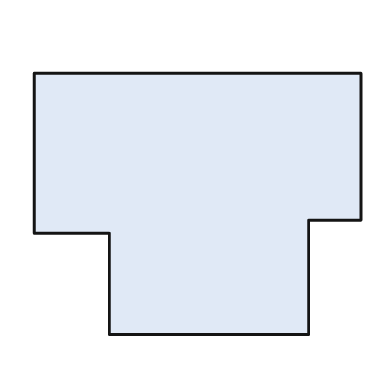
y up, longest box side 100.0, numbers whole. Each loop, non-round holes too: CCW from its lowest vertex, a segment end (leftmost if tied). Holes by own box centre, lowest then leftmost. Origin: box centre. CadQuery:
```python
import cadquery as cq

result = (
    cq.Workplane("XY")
    .moveTo(-27.0, -40.0)
    .lineTo(34.0, -40.0)
    .lineTo(34.0, -5.0)
    .lineTo(50.0, -5.0)
    .lineTo(50.0, 40.0)
    .lineTo(-50.0, 40.0)
    .lineTo(-50.0, -9.0)
    .lineTo(-27.0, -9.0)
    .close()
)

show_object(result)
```